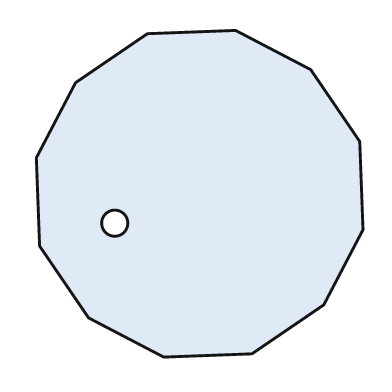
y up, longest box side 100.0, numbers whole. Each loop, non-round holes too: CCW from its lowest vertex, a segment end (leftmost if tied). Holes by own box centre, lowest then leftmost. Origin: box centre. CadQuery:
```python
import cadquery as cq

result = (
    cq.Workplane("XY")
    .moveTo(-11.0, -50.0)
    .lineTo(16.0, -49.0)
    .lineTo(38.0, -34.0)
    .lineTo(50.0, -11.0)
    .lineTo(49.0, 16.0)
    .lineTo(34.0, 38.0)
    .lineTo(11.0, 50.0)
    .lineTo(-16.0, 49.0)
    .lineTo(-38.0, 34.0)
    .lineTo(-50.0, 11.0)
    .lineTo(-49.0, -16.0)
    .lineTo(-34.0, -38.0)
    .close()
    .moveTo(-26.0, -9.0)
    .circle(4.0)
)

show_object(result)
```